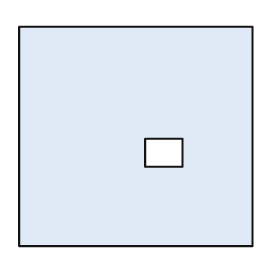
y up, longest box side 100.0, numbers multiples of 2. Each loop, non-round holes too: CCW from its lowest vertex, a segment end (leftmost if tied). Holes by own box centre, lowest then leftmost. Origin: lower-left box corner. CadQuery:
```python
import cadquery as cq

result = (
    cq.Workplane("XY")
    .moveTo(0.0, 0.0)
    .lineTo(100.0, 0.0)
    .lineTo(100.0, 94.0)
    .lineTo(0.0, 94.0)
    .close()
    .moveTo(54.0, 34.0)
    .lineTo(70.0, 34.0)
    .lineTo(70.0, 46.0)
    .lineTo(54.0, 46.0)
    .close()
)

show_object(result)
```